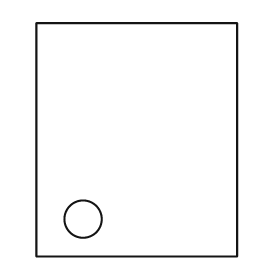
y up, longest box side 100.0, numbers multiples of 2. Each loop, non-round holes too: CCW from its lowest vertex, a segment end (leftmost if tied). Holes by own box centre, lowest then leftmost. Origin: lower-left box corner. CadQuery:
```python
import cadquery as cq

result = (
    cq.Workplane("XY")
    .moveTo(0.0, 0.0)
    .lineTo(86.0, 0.0)
    .lineTo(86.0, 100.0)
    .lineTo(0.0, 100.0)
    .close()
    .moveTo(20.0, 16.0)
    .circle(8.0)
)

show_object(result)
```